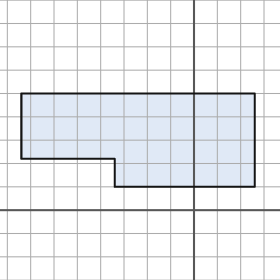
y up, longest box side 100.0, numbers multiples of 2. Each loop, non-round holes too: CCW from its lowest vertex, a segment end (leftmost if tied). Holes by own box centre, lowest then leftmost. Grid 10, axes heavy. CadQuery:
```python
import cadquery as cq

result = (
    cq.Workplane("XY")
    .moveTo(-34.0, 10.0)
    .lineTo(26.0, 10.0)
    .lineTo(26.0, 50.0)
    .lineTo(-74.0, 50.0)
    .lineTo(-74.0, 22.0)
    .lineTo(-34.0, 22.0)
    .close()
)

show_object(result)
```